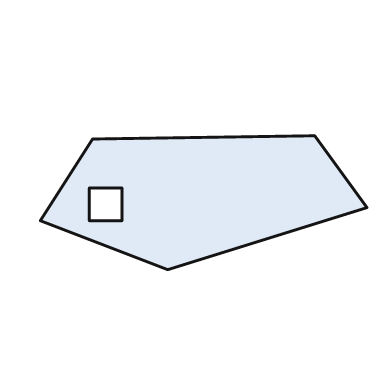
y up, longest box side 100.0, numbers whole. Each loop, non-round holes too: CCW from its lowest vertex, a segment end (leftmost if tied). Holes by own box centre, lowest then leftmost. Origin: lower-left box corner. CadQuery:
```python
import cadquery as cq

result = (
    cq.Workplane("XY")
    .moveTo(39.0, 0.0)
    .lineTo(100.0, 19.0)
    .lineTo(84.0, 41.0)
    .lineTo(16.0, 40.0)
    .lineTo(0.0, 15.0)
    .close()
    .moveTo(15.0, 15.0)
    .lineTo(25.0, 15.0)
    .lineTo(25.0, 25.0)
    .lineTo(15.0, 25.0)
    .close()
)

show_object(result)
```